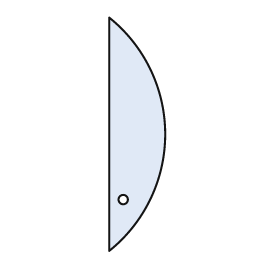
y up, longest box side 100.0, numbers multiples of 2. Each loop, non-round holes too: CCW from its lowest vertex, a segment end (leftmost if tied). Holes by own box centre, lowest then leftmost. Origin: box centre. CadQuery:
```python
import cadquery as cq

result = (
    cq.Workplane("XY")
    .moveTo(-12.0, -50.0)
    .threePointArc((12.0, 0.0), (-12.0, 50.0))
    .close()
    .moveTo(-6.0, -28.0)
    .circle(2.0)
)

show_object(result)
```